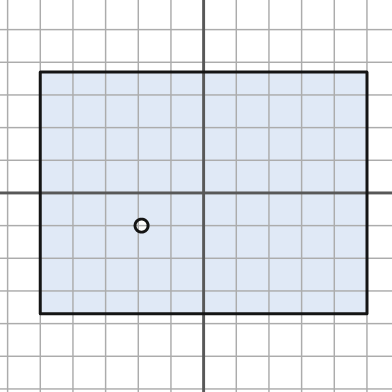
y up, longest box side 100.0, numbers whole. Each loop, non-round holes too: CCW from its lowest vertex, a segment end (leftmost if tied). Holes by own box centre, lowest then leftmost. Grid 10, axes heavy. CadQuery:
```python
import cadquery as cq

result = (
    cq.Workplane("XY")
    .moveTo(-50.0, -37.0)
    .lineTo(50.0, -37.0)
    .lineTo(50.0, 37.0)
    .lineTo(-50.0, 37.0)
    .close()
    .moveTo(-19.0, -10.0)
    .circle(2.0)
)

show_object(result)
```